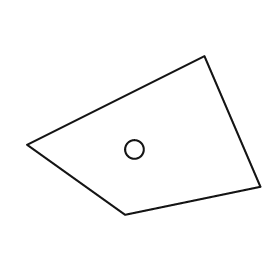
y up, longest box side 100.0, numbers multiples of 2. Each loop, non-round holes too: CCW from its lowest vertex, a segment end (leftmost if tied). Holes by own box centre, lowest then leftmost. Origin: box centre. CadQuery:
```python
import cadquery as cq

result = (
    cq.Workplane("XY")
    .moveTo(-8.0, -34.0)
    .lineTo(50.0, -22.0)
    .lineTo(26.0, 34.0)
    .lineTo(-50.0, -4.0)
    .close()
    .moveTo(-4.0, -6.0)
    .circle(4.0)
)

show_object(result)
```